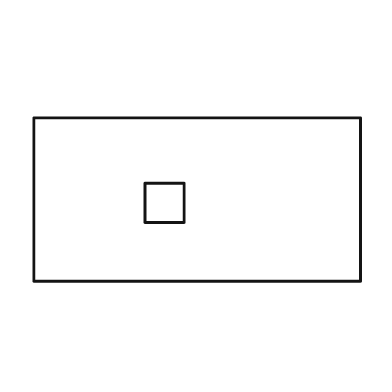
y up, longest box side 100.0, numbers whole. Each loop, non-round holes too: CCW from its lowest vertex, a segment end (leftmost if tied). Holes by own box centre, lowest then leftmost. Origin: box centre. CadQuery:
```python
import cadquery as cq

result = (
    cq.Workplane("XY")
    .moveTo(-50.0, -25.0)
    .lineTo(50.0, -25.0)
    .lineTo(50.0, 25.0)
    .lineTo(-50.0, 25.0)
    .close()
    .moveTo(-16.0, -7.0)
    .lineTo(-4.0, -7.0)
    .lineTo(-4.0, 5.0)
    .lineTo(-16.0, 5.0)
    .close()
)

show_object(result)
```